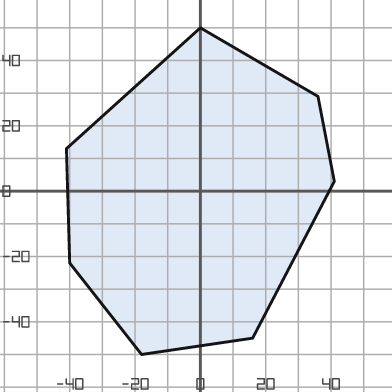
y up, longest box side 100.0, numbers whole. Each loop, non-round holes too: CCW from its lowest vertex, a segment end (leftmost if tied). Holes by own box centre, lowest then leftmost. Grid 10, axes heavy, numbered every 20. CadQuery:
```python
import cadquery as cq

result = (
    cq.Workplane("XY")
    .moveTo(-18.0, -50.0)
    .lineTo(16.0, -45.0)
    .lineTo(41.0, 3.0)
    .lineTo(36.0, 29.0)
    .lineTo(0.0, 50.0)
    .lineTo(-41.0, 13.0)
    .lineTo(-40.0, -22.0)
    .close()
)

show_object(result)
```